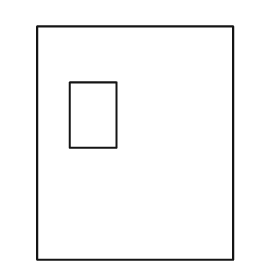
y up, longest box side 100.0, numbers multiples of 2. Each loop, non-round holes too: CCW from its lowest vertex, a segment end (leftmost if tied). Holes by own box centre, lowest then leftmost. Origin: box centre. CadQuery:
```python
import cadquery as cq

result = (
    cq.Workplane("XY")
    .moveTo(-42.0, -50.0)
    .lineTo(42.0, -50.0)
    .lineTo(42.0, 50.0)
    .lineTo(-42.0, 50.0)
    .close()
    .moveTo(-28.0, -2.0)
    .lineTo(-8.0, -2.0)
    .lineTo(-8.0, 26.0)
    .lineTo(-28.0, 26.0)
    .close()
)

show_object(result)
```